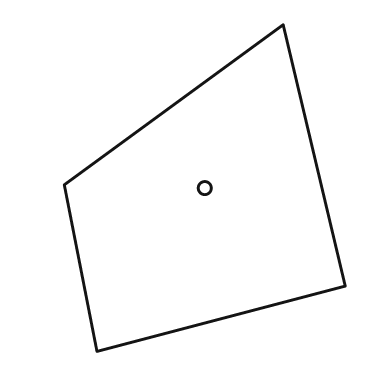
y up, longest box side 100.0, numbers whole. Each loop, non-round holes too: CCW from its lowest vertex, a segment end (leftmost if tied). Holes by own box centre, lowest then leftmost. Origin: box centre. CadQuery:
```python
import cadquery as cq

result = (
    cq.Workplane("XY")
    .moveTo(-33.0, -50.0)
    .lineTo(43.0, -30.0)
    .lineTo(24.0, 50.0)
    .lineTo(-43.0, 1.0)
    .close()
    .moveTo(0.0, 0.0)
    .circle(2.0)
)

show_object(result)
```